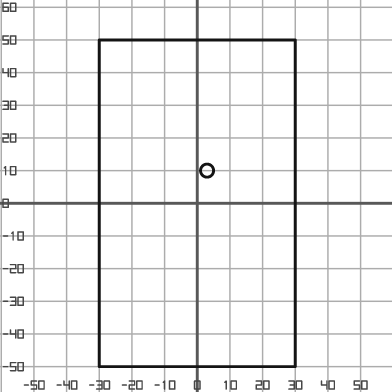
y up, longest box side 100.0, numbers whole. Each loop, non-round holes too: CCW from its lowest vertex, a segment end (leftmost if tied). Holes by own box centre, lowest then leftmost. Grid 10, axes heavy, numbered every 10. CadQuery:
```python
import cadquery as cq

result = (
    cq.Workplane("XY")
    .moveTo(-30.0, -50.0)
    .lineTo(30.0, -50.0)
    .lineTo(30.0, 50.0)
    .lineTo(-30.0, 50.0)
    .close()
    .moveTo(3.0, 10.0)
    .circle(2.0)
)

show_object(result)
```